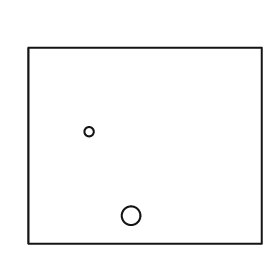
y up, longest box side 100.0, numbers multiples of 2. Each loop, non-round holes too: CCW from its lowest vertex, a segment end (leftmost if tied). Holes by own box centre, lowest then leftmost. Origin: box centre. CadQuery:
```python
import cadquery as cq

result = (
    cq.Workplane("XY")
    .moveTo(-50.0, -42.0)
    .lineTo(50.0, -42.0)
    .lineTo(50.0, 42.0)
    .lineTo(-50.0, 42.0)
    .close()
    .moveTo(-6.0, -30.0)
    .circle(4.0)
    .moveTo(-24.0, 6.0)
    .circle(2.0)
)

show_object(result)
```